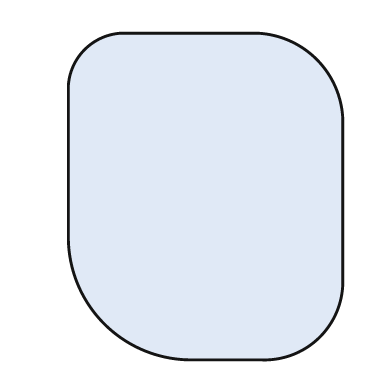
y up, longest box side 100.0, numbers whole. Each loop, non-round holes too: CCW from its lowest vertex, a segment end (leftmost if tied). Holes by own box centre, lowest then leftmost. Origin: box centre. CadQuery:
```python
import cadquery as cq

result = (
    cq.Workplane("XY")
    .moveTo(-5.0, -50.0)
    .lineTo(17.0, -50.0)
    .threePointArc((35.0, -43.0), (42.0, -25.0))
    .lineTo(42.0, 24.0)
    .threePointArc((34.0, 42.0), (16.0, 50.0))
    .lineTo(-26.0, 50.0)
    .threePointArc((-37.0, 45.0), (-42.0, 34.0))
    .lineTo(-42.0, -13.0)
    .threePointArc((-31.0, -39.0), (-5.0, -50.0))
    .close()
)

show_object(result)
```